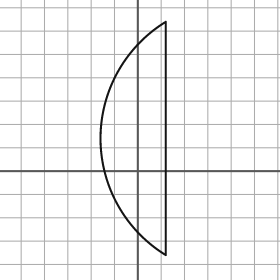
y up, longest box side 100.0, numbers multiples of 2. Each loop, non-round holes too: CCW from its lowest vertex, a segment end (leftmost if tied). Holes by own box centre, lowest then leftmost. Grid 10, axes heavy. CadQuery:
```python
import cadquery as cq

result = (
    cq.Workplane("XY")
    .moveTo(12.0, -36.0)
    .lineTo(12.0, 64.0)
    .threePointArc((-16.0, 14.0), (12.0, -36.0))
    .close()
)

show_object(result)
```